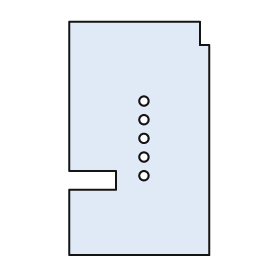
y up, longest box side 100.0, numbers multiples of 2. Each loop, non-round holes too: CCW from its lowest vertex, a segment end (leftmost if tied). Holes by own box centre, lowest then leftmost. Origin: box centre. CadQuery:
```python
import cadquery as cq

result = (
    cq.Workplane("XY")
    .moveTo(-30.0, -50.0)
    .lineTo(30.0, -50.0)
    .lineTo(30.0, 40.0)
    .lineTo(26.0, 40.0)
    .lineTo(26.0, 50.0)
    .lineTo(-30.0, 50.0)
    .lineTo(-30.0, -14.0)
    .lineTo(-10.0, -14.0)
    .lineTo(-10.0, -22.0)
    .lineTo(-30.0, -22.0)
    .close()
    .moveTo(2.0, -16.0)
    .circle(2.0)
    .moveTo(2.0, -8.0)
    .circle(2.0)
    .moveTo(2.0, 0.0)
    .circle(2.0)
    .moveTo(2.0, 8.0)
    .circle(2.0)
    .moveTo(2.0, 16.0)
    .circle(2.0)
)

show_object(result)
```